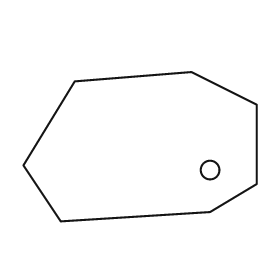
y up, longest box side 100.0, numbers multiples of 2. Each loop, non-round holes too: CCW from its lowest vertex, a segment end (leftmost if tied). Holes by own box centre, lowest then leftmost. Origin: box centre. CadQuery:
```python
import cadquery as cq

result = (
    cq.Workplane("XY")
    .moveTo(-34.0, -32.0)
    .lineTo(30.0, -28.0)
    .lineTo(50.0, -16.0)
    .lineTo(50.0, 18.0)
    .lineTo(22.0, 32.0)
    .lineTo(-28.0, 28.0)
    .lineTo(-50.0, -8.0)
    .close()
    .moveTo(30.0, -10.0)
    .circle(4.0)
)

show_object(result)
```